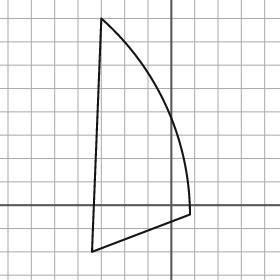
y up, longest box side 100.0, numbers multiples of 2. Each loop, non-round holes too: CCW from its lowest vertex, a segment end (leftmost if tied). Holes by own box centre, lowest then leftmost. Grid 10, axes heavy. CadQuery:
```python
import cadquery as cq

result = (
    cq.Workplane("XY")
    .moveTo(-34.0, -20.0)
    .lineTo(8.0, -4.0)
    .threePointArc((-2.0, 42.0), (-30.0, 80.0))
    .close()
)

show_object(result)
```